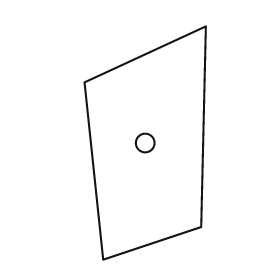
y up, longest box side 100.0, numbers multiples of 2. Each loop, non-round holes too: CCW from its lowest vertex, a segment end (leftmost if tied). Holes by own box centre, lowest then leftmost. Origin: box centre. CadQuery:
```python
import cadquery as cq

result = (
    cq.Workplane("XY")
    .moveTo(-18.0, -50.0)
    .lineTo(24.0, -36.0)
    .lineTo(26.0, 50.0)
    .lineTo(-26.0, 26.0)
    .close()
    .moveTo(0.0, 0.0)
    .circle(4.0)
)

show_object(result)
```